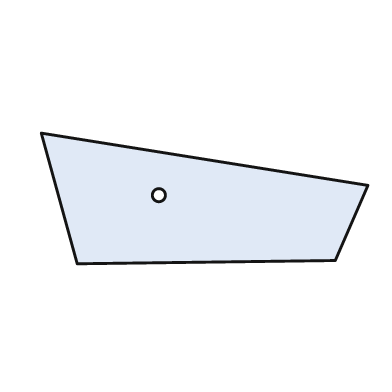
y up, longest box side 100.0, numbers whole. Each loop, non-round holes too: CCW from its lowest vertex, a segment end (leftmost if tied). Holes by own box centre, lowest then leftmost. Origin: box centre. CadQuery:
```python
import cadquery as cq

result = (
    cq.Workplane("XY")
    .moveTo(-39.0, -20.0)
    .lineTo(40.0, -19.0)
    .lineTo(50.0, 4.0)
    .lineTo(-50.0, 20.0)
    .close()
    .moveTo(-14.0, 1.0)
    .circle(2.0)
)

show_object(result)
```